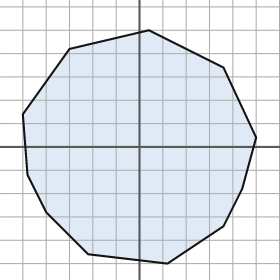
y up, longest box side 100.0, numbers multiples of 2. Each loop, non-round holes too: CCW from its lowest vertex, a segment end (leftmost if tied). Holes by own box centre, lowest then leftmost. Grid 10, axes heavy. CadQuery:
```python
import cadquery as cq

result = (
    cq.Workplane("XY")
    .moveTo(12.0, -50.0)
    .lineTo(36.0, -34.0)
    .lineTo(44.0, -18.0)
    .lineTo(50.0, 4.0)
    .lineTo(36.0, 34.0)
    .lineTo(4.0, 50.0)
    .lineTo(-30.0, 42.0)
    .lineTo(-50.0, 14.0)
    .lineTo(-48.0, -12.0)
    .lineTo(-40.0, -28.0)
    .lineTo(-22.0, -46.0)
    .close()
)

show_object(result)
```